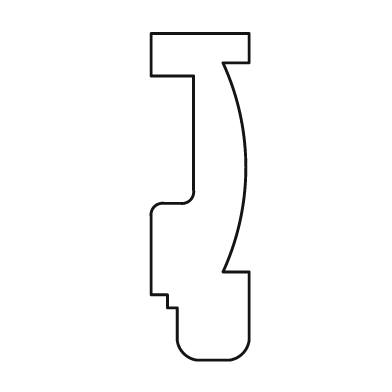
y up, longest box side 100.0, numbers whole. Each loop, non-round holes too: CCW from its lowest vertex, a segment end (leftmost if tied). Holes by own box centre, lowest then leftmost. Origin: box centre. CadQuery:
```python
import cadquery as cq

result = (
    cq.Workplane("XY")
    .moveTo(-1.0, -50.0)
    .lineTo(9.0, -50.0)
    .threePointArc((13.0, -48.0), (15.0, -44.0))
    .lineTo(15.0, -23.0)
    .lineTo(7.0, -23.0)
    .threePointArc((14.0, 9.0), (7.0, 41.0))
    .lineTo(15.0, 41.0)
    .lineTo(15.0, 50.0)
    .lineTo(-15.0, 50.0)
    .lineTo(-15.0, 37.0)
    .lineTo(-2.0, 37.0)
    .lineTo(-2.0, 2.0)
    .threePointArc((-3.0, -1.0), (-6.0, -2.0))
    .lineTo(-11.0, -2.0)
    .threePointArc((-14.0, -3.0), (-15.0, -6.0))
    .lineTo(-15.0, -30.0)
    .lineTo(-10.0, -30.0)
    .lineTo(-10.0, -34.0)
    .lineTo(-7.0, -34.0)
    .lineTo(-7.0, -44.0)
    .threePointArc((-5.0, -48.0), (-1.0, -50.0))
    .close()
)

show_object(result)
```